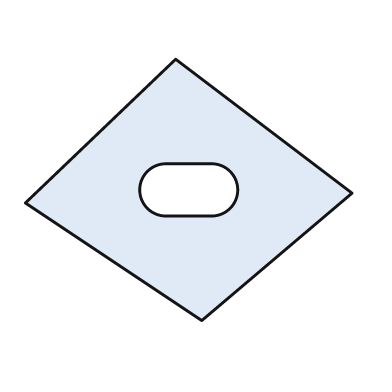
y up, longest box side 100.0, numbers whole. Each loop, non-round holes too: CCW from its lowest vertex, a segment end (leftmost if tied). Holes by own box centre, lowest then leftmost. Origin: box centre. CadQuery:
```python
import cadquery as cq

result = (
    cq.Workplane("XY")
    .moveTo(4.0, -40.0)
    .lineTo(50.0, -1.0)
    .lineTo(-4.0, 40.0)
    .lineTo(-50.0, -4.0)
    .close()
    .moveTo(-7.0, -8.0)
    .lineTo(7.0, -8.0)
    .threePointArc((15.0, 0.0), (7.0, 8.0))
    .lineTo(-7.0, 8.0)
    .threePointArc((-15.0, 0.0), (-7.0, -8.0))
    .close()
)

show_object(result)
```